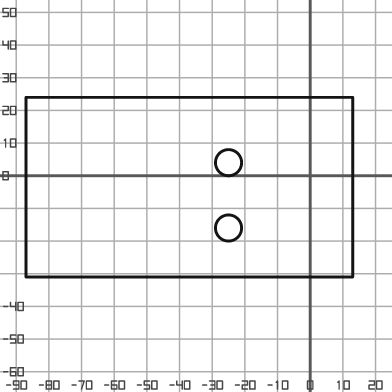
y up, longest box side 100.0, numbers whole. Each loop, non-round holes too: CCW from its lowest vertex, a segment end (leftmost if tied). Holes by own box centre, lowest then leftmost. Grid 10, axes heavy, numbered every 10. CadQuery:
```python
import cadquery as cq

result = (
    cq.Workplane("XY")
    .moveTo(-87.0, -31.0)
    .lineTo(13.0, -31.0)
    .lineTo(13.0, 24.0)
    .lineTo(-87.0, 24.0)
    .close()
    .moveTo(-25.0, -16.0)
    .circle(4.0)
    .moveTo(-25.0, 4.0)
    .circle(4.0)
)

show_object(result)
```